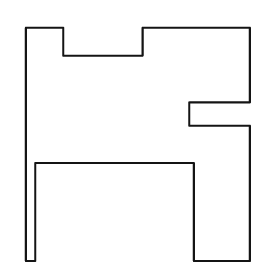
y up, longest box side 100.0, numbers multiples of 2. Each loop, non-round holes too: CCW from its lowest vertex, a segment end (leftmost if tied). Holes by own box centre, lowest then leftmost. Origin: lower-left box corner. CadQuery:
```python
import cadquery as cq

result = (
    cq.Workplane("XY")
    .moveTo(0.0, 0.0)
    .lineTo(4.0, 0.0)
    .lineTo(4.0, 42.0)
    .lineTo(72.0, 42.0)
    .lineTo(72.0, 0.0)
    .lineTo(96.0, 0.0)
    .lineTo(96.0, 58.0)
    .lineTo(70.0, 58.0)
    .lineTo(70.0, 68.0)
    .lineTo(96.0, 68.0)
    .lineTo(96.0, 100.0)
    .lineTo(50.0, 100.0)
    .lineTo(50.0, 88.0)
    .lineTo(16.0, 88.0)
    .lineTo(16.0, 100.0)
    .lineTo(0.0, 100.0)
    .close()
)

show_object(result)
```